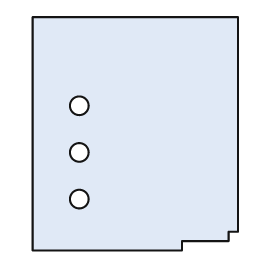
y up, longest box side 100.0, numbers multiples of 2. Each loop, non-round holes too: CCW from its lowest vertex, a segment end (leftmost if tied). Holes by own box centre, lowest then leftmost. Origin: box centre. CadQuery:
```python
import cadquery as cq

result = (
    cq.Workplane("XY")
    .moveTo(-44.0, -50.0)
    .lineTo(20.0, -50.0)
    .lineTo(20.0, -46.0)
    .lineTo(40.0, -46.0)
    .lineTo(40.0, -42.0)
    .lineTo(44.0, -42.0)
    .lineTo(44.0, 50.0)
    .lineTo(-44.0, 50.0)
    .close()
    .moveTo(-24.0, -28.0)
    .circle(4.0)
    .moveTo(-24.0, -8.0)
    .circle(4.0)
    .moveTo(-24.0, 12.0)
    .circle(4.0)
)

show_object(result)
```